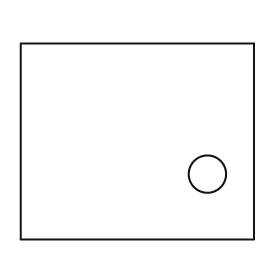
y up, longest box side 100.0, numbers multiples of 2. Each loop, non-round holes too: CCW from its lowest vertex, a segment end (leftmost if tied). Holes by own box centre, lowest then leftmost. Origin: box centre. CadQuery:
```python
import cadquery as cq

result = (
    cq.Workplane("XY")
    .moveTo(-50.0, -42.0)
    .lineTo(50.0, -42.0)
    .lineTo(50.0, 42.0)
    .lineTo(-50.0, 42.0)
    .close()
    .moveTo(30.0, -14.0)
    .circle(8.0)
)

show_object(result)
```